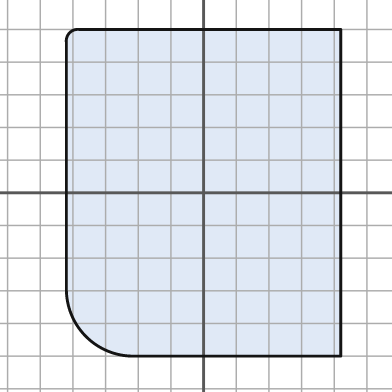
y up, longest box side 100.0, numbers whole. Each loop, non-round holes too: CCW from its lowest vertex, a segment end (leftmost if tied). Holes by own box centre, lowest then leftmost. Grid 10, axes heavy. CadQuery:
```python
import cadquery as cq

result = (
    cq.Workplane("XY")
    .moveTo(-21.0, -50.0)
    .lineTo(42.0, -50.0)
    .lineTo(42.0, 50.0)
    .lineTo(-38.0, 50.0)
    .threePointArc((-41.0, 49.0), (-42.0, 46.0))
    .lineTo(-42.0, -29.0)
    .threePointArc((-36.0, -44.0), (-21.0, -50.0))
    .close()
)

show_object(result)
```